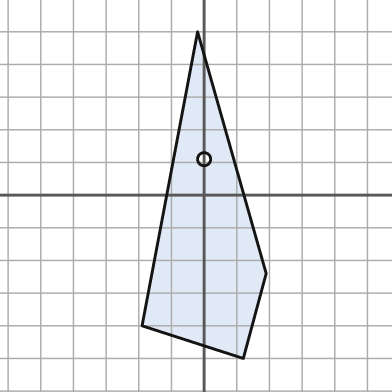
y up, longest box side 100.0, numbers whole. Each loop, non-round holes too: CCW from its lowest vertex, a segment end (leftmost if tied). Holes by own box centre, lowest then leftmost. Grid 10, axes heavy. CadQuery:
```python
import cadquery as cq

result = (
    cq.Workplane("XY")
    .moveTo(12.0, -50.0)
    .lineTo(19.0, -24.0)
    .lineTo(-2.0, 50.0)
    .lineTo(-19.0, -40.0)
    .close()
    .moveTo(0.0, 11.0)
    .circle(2.0)
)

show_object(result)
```